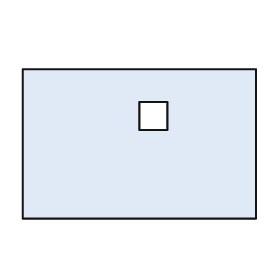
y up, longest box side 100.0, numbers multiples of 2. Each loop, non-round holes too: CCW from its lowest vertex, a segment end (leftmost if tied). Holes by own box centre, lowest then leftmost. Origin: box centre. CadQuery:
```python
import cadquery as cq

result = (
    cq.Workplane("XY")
    .moveTo(-50.0, -32.0)
    .lineTo(50.0, -32.0)
    .lineTo(50.0, 32.0)
    .lineTo(-50.0, 32.0)
    .close()
    .moveTo(0.0, 6.0)
    .lineTo(12.0, 6.0)
    .lineTo(12.0, 18.0)
    .lineTo(0.0, 18.0)
    .close()
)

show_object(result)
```